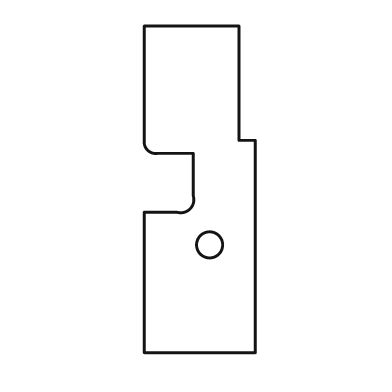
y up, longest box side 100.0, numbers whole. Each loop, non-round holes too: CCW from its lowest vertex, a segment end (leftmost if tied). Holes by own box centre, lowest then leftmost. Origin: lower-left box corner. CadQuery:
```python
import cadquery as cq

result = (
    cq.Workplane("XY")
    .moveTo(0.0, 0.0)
    .lineTo(34.0, 0.0)
    .lineTo(34.0, 65.0)
    .lineTo(29.0, 65.0)
    .lineTo(29.0, 100.0)
    .lineTo(0.0, 100.0)
    .lineTo(0.0, 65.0)
    .threePointArc((1.0, 62.0), (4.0, 61.0))
    .lineTo(15.0, 61.0)
    .lineTo(15.0, 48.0)
    .threePointArc((14.0, 44.0), (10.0, 43.0))
    .lineTo(0.0, 43.0)
    .close()
    .moveTo(20.0, 33.0)
    .circle(4.0)
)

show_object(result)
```